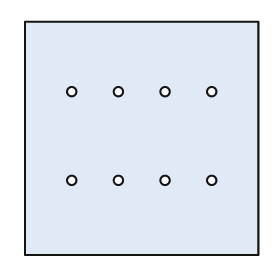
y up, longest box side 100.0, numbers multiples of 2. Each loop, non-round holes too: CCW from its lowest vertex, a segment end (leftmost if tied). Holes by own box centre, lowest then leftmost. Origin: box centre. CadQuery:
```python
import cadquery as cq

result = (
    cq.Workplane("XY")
    .moveTo(-50.0, -50.0)
    .lineTo(50.0, -50.0)
    .lineTo(50.0, 50.0)
    .lineTo(-50.0, 50.0)
    .close()
    .moveTo(-30.0, -18.0)
    .circle(2.0)
    .moveTo(-10.0, -18.0)
    .circle(2.0)
    .moveTo(10.0, -18.0)
    .circle(2.0)
    .moveTo(30.0, -18.0)
    .circle(2.0)
    .moveTo(-30.0, 20.0)
    .circle(2.0)
    .moveTo(-10.0, 20.0)
    .circle(2.0)
    .moveTo(10.0, 20.0)
    .circle(2.0)
    .moveTo(30.0, 20.0)
    .circle(2.0)
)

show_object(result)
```